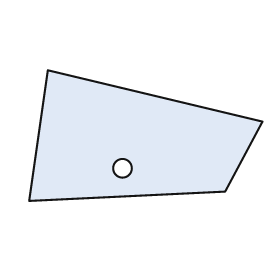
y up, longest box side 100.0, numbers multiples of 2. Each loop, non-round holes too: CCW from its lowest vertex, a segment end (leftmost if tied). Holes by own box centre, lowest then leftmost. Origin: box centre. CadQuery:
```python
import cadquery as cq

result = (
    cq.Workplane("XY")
    .moveTo(-50.0, -28.0)
    .lineTo(34.0, -24.0)
    .lineTo(50.0, 6.0)
    .lineTo(-42.0, 28.0)
    .close()
    .moveTo(-10.0, -14.0)
    .circle(4.0)
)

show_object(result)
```